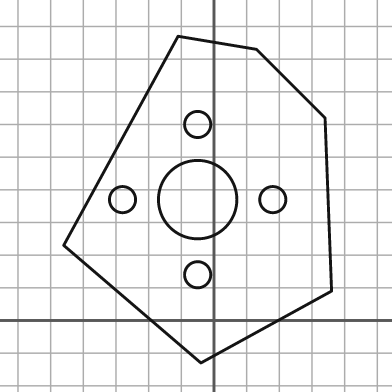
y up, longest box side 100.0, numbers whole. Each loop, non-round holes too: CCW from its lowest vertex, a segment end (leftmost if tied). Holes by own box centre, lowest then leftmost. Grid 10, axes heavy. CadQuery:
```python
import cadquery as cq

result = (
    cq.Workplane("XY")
    .moveTo(-4.0, -13.0)
    .lineTo(36.0, 9.0)
    .lineTo(34.0, 62.0)
    .lineTo(13.0, 83.0)
    .lineTo(-11.0, 87.0)
    .lineTo(-46.0, 23.0)
    .close()
    .moveTo(-5.0, 14.0)
    .circle(4.0)
    .moveTo(-28.0, 37.0)
    .circle(4.0)
    .moveTo(-5.0, 37.0)
    .circle(12.0)
    .moveTo(18.0, 37.0)
    .circle(4.0)
    .moveTo(-5.0, 60.0)
    .circle(4.0)
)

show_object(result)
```